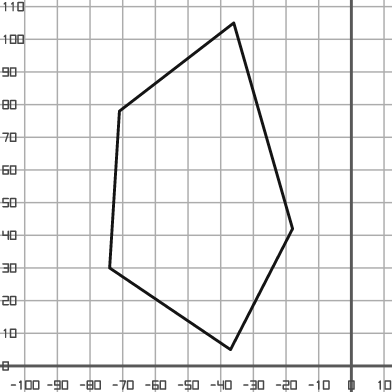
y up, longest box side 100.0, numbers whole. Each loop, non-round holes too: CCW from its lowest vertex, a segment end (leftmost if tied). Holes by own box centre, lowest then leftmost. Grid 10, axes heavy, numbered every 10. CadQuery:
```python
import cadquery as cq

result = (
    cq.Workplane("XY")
    .moveTo(-37.0, 5.0)
    .lineTo(-18.0, 42.0)
    .lineTo(-36.0, 105.0)
    .lineTo(-71.0, 78.0)
    .lineTo(-74.0, 30.0)
    .close()
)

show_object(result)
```